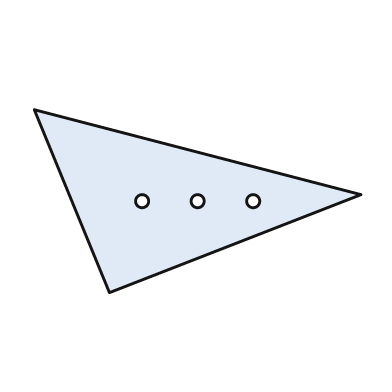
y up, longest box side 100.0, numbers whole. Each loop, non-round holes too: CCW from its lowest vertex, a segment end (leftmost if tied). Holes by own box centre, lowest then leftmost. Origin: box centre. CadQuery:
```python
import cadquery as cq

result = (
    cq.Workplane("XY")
    .moveTo(-27.0, -28.0)
    .lineTo(50.0, 2.0)
    .lineTo(-50.0, 28.0)
    .close()
    .moveTo(-17.0, 0.0)
    .circle(2.0)
    .moveTo(0.0, 0.0)
    .circle(2.0)
    .moveTo(17.0, 0.0)
    .circle(2.0)
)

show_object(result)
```